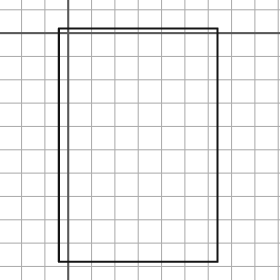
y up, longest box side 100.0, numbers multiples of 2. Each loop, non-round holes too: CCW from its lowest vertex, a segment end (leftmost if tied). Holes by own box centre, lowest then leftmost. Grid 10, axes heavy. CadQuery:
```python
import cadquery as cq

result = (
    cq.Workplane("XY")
    .moveTo(-4.0, -98.0)
    .lineTo(64.0, -98.0)
    .lineTo(64.0, 2.0)
    .lineTo(-4.0, 2.0)
    .close()
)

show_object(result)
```